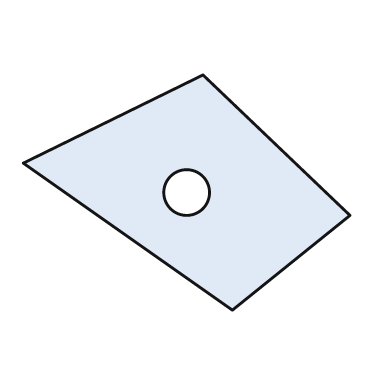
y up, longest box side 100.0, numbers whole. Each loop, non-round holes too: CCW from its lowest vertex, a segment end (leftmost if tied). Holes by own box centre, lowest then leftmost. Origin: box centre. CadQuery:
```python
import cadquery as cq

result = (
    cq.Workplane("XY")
    .moveTo(14.0, -36.0)
    .lineTo(50.0, -7.0)
    .lineTo(5.0, 36.0)
    .lineTo(-50.0, 9.0)
    .close()
    .moveTo(0.0, 0.0)
    .circle(7.0)
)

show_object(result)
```